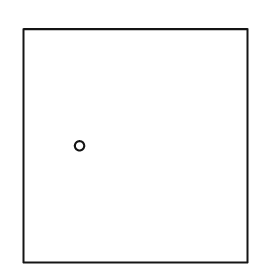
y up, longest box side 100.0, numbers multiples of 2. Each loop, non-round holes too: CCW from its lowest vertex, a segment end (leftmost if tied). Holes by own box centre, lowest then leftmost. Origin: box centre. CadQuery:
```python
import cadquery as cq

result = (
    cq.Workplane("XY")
    .moveTo(-48.0, -50.0)
    .lineTo(48.0, -50.0)
    .lineTo(48.0, 50.0)
    .lineTo(-48.0, 50.0)
    .close()
    .moveTo(-24.0, 0.0)
    .circle(2.0)
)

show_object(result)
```